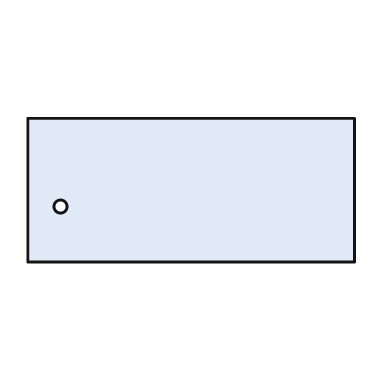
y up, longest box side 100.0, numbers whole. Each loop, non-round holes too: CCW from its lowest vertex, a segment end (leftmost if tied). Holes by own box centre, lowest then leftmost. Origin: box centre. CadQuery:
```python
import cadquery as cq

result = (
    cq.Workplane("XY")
    .moveTo(-50.0, -22.0)
    .lineTo(50.0, -22.0)
    .lineTo(50.0, 22.0)
    .lineTo(-50.0, 22.0)
    .close()
    .moveTo(-40.0, -5.0)
    .circle(2.0)
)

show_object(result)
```